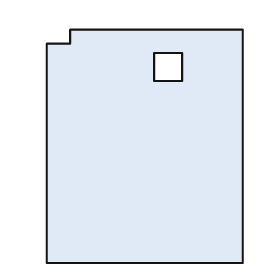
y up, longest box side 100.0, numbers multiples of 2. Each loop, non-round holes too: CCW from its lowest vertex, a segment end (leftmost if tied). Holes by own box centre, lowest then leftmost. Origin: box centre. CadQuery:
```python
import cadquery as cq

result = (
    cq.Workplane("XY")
    .moveTo(-42.0, -50.0)
    .lineTo(42.0, -50.0)
    .lineTo(42.0, 50.0)
    .lineTo(-32.0, 50.0)
    .lineTo(-32.0, 44.0)
    .lineTo(-42.0, 44.0)
    .close()
    .moveTo(4.0, 28.0)
    .lineTo(16.0, 28.0)
    .lineTo(16.0, 40.0)
    .lineTo(4.0, 40.0)
    .close()
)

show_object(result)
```